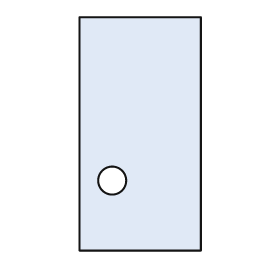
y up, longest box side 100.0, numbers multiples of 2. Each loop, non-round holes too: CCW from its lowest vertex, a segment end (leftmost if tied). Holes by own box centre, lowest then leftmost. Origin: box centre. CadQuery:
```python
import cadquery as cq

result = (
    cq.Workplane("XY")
    .moveTo(-26.0, -50.0)
    .lineTo(26.0, -50.0)
    .lineTo(26.0, 50.0)
    .lineTo(-26.0, 50.0)
    .close()
    .moveTo(-12.0, -20.0)
    .circle(6.0)
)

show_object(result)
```